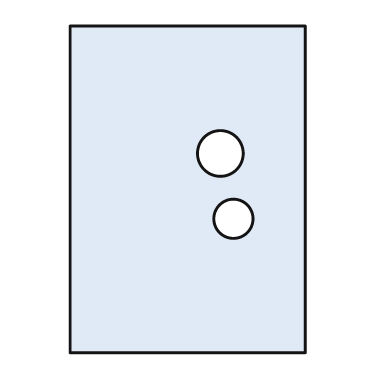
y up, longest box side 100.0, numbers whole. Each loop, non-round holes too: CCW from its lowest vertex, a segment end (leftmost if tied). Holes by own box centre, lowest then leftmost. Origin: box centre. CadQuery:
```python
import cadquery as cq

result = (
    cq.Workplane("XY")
    .moveTo(-36.0, -50.0)
    .lineTo(36.0, -50.0)
    .lineTo(36.0, 50.0)
    .lineTo(-36.0, 50.0)
    .close()
    .moveTo(14.0, -9.0)
    .circle(6.0)
    .moveTo(10.0, 11.0)
    .circle(7.0)
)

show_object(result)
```